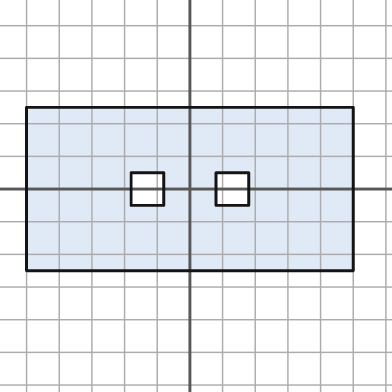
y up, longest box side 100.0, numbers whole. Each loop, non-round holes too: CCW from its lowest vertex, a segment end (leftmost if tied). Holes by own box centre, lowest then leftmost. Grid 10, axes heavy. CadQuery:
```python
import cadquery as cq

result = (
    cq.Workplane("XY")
    .moveTo(-50.0, -25.0)
    .lineTo(50.0, -25.0)
    .lineTo(50.0, 25.0)
    .lineTo(-50.0, 25.0)
    .close()
    .moveTo(-18.0, -5.0)
    .lineTo(-8.0, -5.0)
    .lineTo(-8.0, 5.0)
    .lineTo(-18.0, 5.0)
    .close()
    .moveTo(8.0, -5.0)
    .lineTo(18.0, -5.0)
    .lineTo(18.0, 5.0)
    .lineTo(8.0, 5.0)
    .close()
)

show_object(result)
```